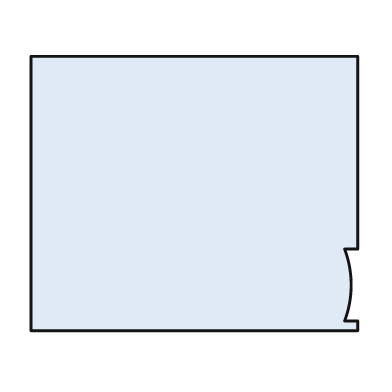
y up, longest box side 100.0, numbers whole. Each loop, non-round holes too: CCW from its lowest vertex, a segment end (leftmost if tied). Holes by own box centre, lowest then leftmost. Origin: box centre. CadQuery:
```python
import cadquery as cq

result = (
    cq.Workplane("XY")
    .moveTo(-50.0, -42.0)
    .lineTo(50.0, -42.0)
    .lineTo(50.0, -39.0)
    .lineTo(46.0, -39.0)
    .threePointArc((48.0, -28.0), (46.0, -17.0))
    .lineTo(50.0, -17.0)
    .lineTo(50.0, 42.0)
    .lineTo(-50.0, 42.0)
    .close()
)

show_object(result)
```